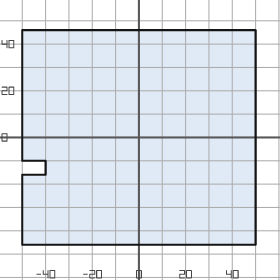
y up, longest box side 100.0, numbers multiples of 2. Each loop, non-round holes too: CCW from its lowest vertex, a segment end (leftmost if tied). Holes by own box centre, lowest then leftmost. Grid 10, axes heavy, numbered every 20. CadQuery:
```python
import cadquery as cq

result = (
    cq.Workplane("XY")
    .moveTo(-50.0, -46.0)
    .lineTo(50.0, -46.0)
    .lineTo(50.0, 46.0)
    .lineTo(-50.0, 46.0)
    .lineTo(-50.0, -10.0)
    .lineTo(-40.0, -10.0)
    .lineTo(-40.0, -16.0)
    .lineTo(-50.0, -16.0)
    .close()
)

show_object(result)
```